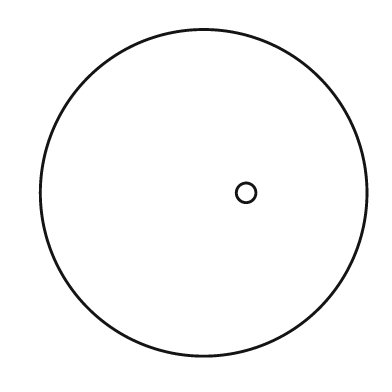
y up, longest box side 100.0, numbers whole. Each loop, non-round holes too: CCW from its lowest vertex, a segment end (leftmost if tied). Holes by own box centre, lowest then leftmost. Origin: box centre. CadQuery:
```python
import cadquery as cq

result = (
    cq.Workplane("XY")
    .moveTo(0.0, 0.0)
    .circle(50.0)
    .moveTo(13.0, 0.0)
    .circle(3.0)
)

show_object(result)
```